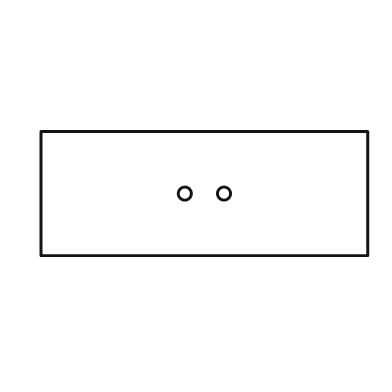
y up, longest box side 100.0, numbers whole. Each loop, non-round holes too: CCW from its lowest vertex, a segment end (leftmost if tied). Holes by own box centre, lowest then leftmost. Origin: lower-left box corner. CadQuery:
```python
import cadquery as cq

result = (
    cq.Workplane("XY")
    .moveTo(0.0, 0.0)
    .lineTo(100.0, 0.0)
    .lineTo(100.0, 38.0)
    .lineTo(0.0, 38.0)
    .close()
    .moveTo(44.0, 19.0)
    .circle(2.0)
    .moveTo(56.0, 19.0)
    .circle(2.0)
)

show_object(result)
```